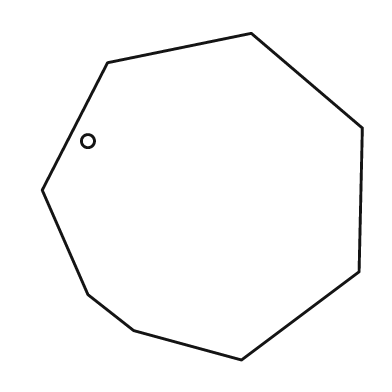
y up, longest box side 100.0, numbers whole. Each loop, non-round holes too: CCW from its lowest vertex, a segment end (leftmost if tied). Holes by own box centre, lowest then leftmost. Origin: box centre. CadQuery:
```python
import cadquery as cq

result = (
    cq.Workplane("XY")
    .moveTo(12.0, -50.0)
    .lineTo(48.0, -23.0)
    .lineTo(49.0, 21.0)
    .lineTo(15.0, 50.0)
    .lineTo(-29.0, 41.0)
    .lineTo(-49.0, 2.0)
    .lineTo(-35.0, -30.0)
    .lineTo(-21.0, -41.0)
    .close()
    .moveTo(-35.0, 17.0)
    .circle(2.0)
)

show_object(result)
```